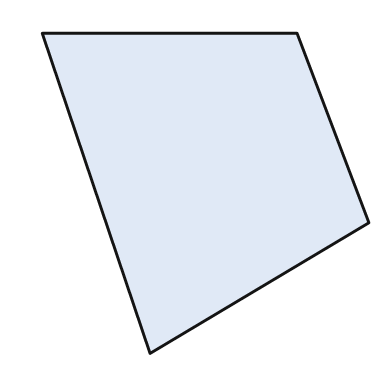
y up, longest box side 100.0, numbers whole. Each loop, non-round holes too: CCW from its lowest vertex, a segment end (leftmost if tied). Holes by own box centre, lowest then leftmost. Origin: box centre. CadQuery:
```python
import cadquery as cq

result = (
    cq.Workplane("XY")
    .moveTo(-17.0, -49.0)
    .lineTo(50.0, -9.0)
    .lineTo(28.0, 49.0)
    .lineTo(-50.0, 49.0)
    .close()
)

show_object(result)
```